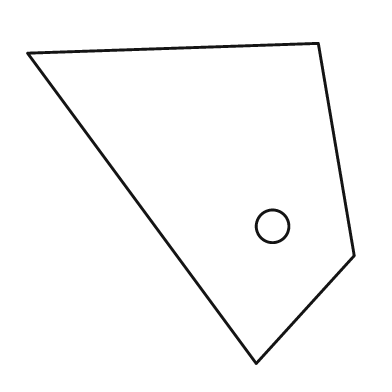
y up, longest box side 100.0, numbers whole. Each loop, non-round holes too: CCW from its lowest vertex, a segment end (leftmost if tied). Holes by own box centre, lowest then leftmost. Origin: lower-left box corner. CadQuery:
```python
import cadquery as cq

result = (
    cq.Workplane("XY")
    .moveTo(70.0, 0.0)
    .lineTo(100.0, 33.0)
    .lineTo(89.0, 98.0)
    .lineTo(0.0, 95.0)
    .close()
    .moveTo(75.0, 42.0)
    .circle(5.0)
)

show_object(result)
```